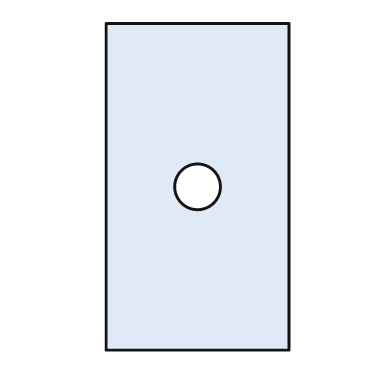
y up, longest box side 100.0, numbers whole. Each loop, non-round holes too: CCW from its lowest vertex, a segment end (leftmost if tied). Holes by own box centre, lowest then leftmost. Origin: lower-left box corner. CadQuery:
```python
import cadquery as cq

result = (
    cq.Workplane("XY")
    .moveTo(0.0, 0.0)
    .lineTo(56.0, 0.0)
    .lineTo(56.0, 100.0)
    .lineTo(0.0, 100.0)
    .close()
    .moveTo(28.0, 50.0)
    .circle(7.0)
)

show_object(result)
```